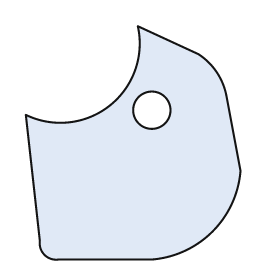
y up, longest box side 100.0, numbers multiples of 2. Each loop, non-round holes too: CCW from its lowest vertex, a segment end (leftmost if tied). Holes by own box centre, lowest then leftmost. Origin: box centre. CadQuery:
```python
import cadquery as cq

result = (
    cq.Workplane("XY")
    .moveTo(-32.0, -50.0)
    .lineTo(8.0, -50.0)
    .threePointArc((34.0, -38.0), (46.0, -12.0))
    .lineTo(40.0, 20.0)
    .threePointArc((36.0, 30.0), (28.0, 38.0))
    .lineTo(2.0, 50.0)
    .threePointArc((-10.0, 16.0), (-46.0, 12.0))
    .lineTo(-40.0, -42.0)
    .threePointArc((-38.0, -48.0), (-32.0, -50.0))
    .close()
    .moveTo(8.0, 14.0)
    .circle(8.0)
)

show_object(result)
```